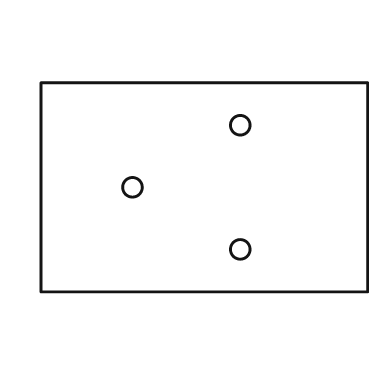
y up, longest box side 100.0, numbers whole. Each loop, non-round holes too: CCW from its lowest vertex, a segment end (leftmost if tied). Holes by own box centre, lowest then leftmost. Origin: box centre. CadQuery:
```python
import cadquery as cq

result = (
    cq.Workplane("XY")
    .moveTo(-50.0, -32.0)
    .lineTo(50.0, -32.0)
    .lineTo(50.0, 32.0)
    .lineTo(-50.0, 32.0)
    .close()
    .moveTo(11.0, -19.0)
    .circle(3.0)
    .moveTo(-22.0, 0.0)
    .circle(3.0)
    .moveTo(11.0, 19.0)
    .circle(3.0)
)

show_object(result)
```